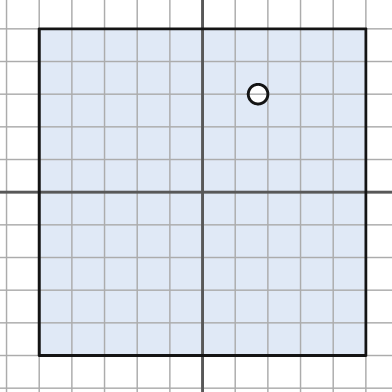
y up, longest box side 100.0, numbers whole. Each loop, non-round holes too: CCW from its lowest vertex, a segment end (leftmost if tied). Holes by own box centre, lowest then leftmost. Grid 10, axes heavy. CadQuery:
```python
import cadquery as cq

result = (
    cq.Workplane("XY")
    .moveTo(-50.0, -50.0)
    .lineTo(50.0, -50.0)
    .lineTo(50.0, 50.0)
    .lineTo(-50.0, 50.0)
    .close()
    .moveTo(17.0, 30.0)
    .circle(3.0)
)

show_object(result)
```